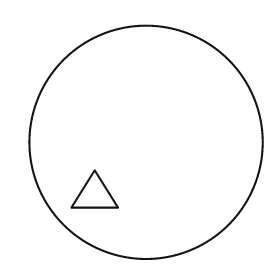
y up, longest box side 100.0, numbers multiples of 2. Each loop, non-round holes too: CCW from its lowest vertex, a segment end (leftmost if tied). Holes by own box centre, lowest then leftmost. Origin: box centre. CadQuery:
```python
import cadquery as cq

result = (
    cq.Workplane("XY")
    .moveTo(0.0, 0.0)
    .circle(50.0)
    .moveTo(-32.0, -28.0)
    .lineTo(-12.0, -28.0)
    .lineTo(-22.0, -12.0)
    .close()
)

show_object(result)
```